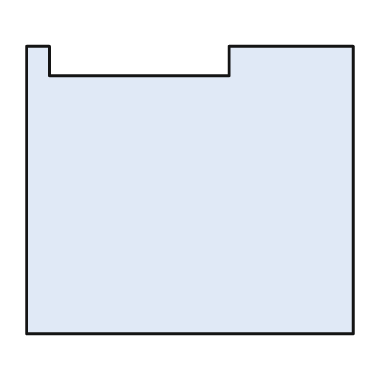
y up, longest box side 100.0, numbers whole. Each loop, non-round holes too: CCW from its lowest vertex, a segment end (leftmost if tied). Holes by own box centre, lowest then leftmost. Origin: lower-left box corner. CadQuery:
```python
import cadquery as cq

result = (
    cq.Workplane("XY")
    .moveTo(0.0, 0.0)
    .lineTo(100.0, 0.0)
    .lineTo(100.0, 88.0)
    .lineTo(62.0, 88.0)
    .lineTo(62.0, 79.0)
    .lineTo(7.0, 79.0)
    .lineTo(7.0, 88.0)
    .lineTo(0.0, 88.0)
    .close()
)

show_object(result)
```